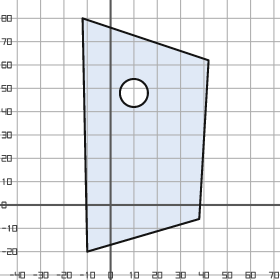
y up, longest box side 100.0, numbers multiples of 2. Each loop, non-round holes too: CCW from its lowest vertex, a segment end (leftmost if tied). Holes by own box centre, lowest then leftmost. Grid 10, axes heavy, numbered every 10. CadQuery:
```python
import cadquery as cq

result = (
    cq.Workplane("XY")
    .moveTo(-10.0, -20.0)
    .lineTo(38.0, -6.0)
    .lineTo(42.0, 62.0)
    .lineTo(-12.0, 80.0)
    .close()
    .moveTo(10.0, 48.0)
    .circle(6.0)
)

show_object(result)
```